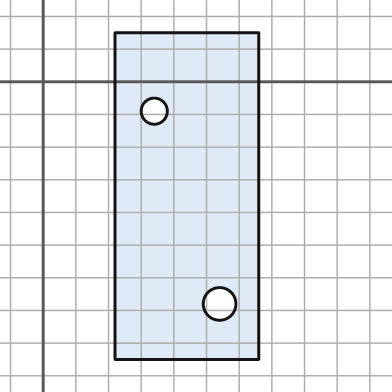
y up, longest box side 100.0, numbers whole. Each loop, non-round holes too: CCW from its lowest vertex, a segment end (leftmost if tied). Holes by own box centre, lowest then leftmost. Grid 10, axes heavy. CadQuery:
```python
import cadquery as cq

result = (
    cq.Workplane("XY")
    .moveTo(22.0, -85.0)
    .lineTo(66.0, -85.0)
    .lineTo(66.0, 15.0)
    .lineTo(22.0, 15.0)
    .close()
    .moveTo(54.0, -68.0)
    .circle(5.0)
    .moveTo(34.0, -9.0)
    .circle(4.0)
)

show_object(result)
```